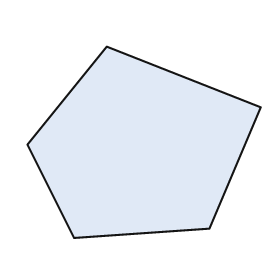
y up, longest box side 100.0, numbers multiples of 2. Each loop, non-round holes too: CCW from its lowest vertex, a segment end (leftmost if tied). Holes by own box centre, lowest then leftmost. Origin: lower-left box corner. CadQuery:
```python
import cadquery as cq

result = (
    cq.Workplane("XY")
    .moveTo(20.0, 0.0)
    .lineTo(78.0, 4.0)
    .lineTo(100.0, 56.0)
    .lineTo(34.0, 82.0)
    .lineTo(0.0, 40.0)
    .close()
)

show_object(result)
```